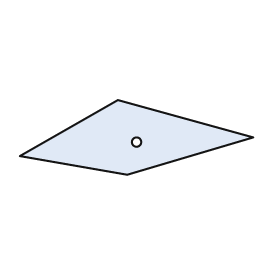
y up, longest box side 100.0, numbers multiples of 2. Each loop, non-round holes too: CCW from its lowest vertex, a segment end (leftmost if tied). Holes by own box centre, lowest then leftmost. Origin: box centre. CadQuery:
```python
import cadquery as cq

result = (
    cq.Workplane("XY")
    .moveTo(-4.0, -16.0)
    .lineTo(50.0, 0.0)
    .lineTo(-8.0, 16.0)
    .lineTo(-50.0, -8.0)
    .close()
    .moveTo(0.0, -2.0)
    .circle(2.0)
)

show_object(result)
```